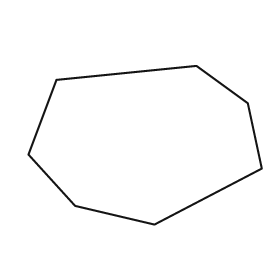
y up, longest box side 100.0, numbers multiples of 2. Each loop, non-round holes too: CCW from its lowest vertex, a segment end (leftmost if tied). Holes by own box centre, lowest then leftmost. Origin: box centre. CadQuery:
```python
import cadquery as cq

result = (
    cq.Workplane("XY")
    .moveTo(4.0, -34.0)
    .lineTo(50.0, -10.0)
    .lineTo(44.0, 18.0)
    .lineTo(22.0, 34.0)
    .lineTo(-38.0, 28.0)
    .lineTo(-50.0, -4.0)
    .lineTo(-30.0, -26.0)
    .close()
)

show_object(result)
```